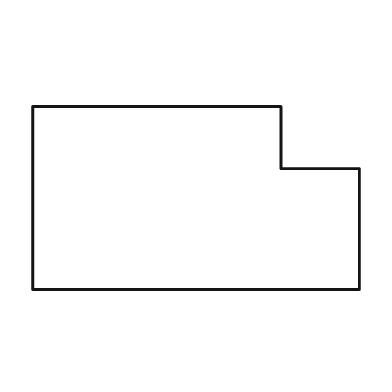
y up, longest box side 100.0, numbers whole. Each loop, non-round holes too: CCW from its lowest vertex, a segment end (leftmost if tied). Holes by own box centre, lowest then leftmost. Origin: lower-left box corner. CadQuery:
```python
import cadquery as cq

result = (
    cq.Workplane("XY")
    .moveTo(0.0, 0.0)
    .lineTo(100.0, 0.0)
    .lineTo(100.0, 37.0)
    .lineTo(76.0, 37.0)
    .lineTo(76.0, 56.0)
    .lineTo(0.0, 56.0)
    .close()
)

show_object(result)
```